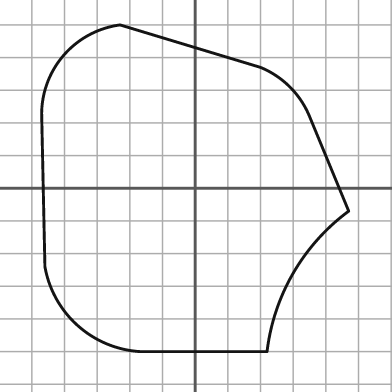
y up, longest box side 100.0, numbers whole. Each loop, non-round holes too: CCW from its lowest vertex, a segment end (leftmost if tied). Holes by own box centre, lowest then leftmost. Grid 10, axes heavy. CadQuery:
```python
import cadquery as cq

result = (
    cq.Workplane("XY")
    .moveTo(-17.0, -50.0)
    .lineTo(22.0, -50.0)
    .threePointArc((30.0, -26.0), (47.0, -7.0))
    .lineTo(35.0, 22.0)
    .threePointArc((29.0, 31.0), (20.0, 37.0))
    .lineTo(-23.0, 50.0)
    .threePointArc((-40.0, 41.0), (-47.0, 23.0))
    .lineTo(-46.0, -24.0)
    .threePointArc((-36.0, -42.0), (-17.0, -50.0))
    .close()
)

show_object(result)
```